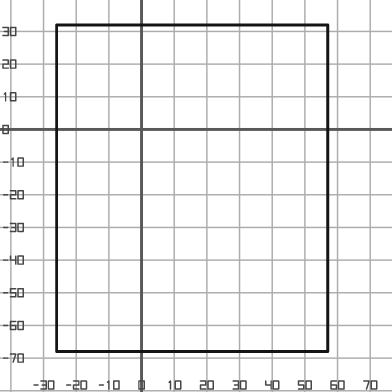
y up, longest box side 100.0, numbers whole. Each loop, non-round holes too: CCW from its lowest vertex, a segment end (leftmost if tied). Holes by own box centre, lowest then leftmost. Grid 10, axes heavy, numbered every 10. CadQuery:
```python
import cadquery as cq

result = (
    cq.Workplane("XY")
    .moveTo(-26.0, -68.0)
    .lineTo(57.0, -68.0)
    .lineTo(57.0, 32.0)
    .lineTo(-26.0, 32.0)
    .close()
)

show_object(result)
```